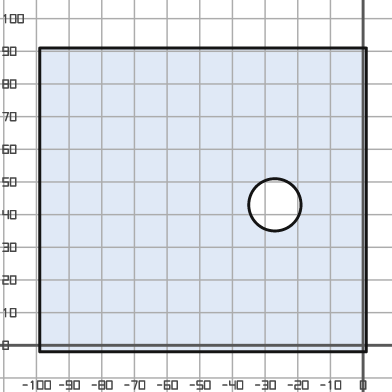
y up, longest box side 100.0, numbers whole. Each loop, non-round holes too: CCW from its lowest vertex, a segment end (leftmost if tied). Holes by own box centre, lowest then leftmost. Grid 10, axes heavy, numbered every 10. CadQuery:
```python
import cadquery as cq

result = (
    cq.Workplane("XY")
    .moveTo(-99.0, -2.0)
    .lineTo(1.0, -2.0)
    .lineTo(1.0, 91.0)
    .lineTo(-99.0, 91.0)
    .close()
    .moveTo(-27.0, 43.0)
    .circle(8.0)
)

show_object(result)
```